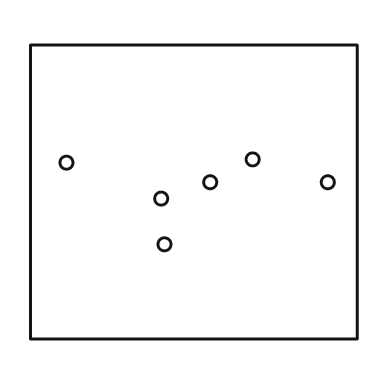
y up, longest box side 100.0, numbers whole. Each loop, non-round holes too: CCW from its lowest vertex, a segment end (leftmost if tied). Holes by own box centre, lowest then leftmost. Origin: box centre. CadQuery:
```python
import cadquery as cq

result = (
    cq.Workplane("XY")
    .moveTo(-50.0, -45.0)
    .lineTo(50.0, -45.0)
    .lineTo(50.0, 45.0)
    .lineTo(-50.0, 45.0)
    .close()
    .moveTo(-9.0, -16.0)
    .circle(2.0)
    .moveTo(-10.0, -2.0)
    .circle(2.0)
    .moveTo(5.0, 3.0)
    .circle(2.0)
    .moveTo(41.0, 3.0)
    .circle(2.0)
    .moveTo(-39.0, 9.0)
    .circle(2.0)
    .moveTo(18.0, 10.0)
    .circle(2.0)
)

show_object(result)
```